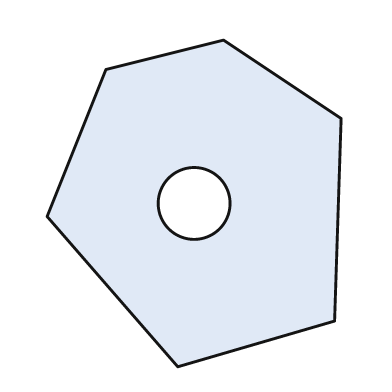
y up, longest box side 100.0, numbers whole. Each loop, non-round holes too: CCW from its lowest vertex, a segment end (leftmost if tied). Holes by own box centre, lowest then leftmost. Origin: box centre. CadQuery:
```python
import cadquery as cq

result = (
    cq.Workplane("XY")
    .moveTo(-5.0, -50.0)
    .lineTo(43.0, -36.0)
    .lineTo(45.0, 26.0)
    .lineTo(9.0, 50.0)
    .lineTo(-27.0, 41.0)
    .lineTo(-45.0, -4.0)
    .close()
    .moveTo(0.0, 0.0)
    .circle(11.0)
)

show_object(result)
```